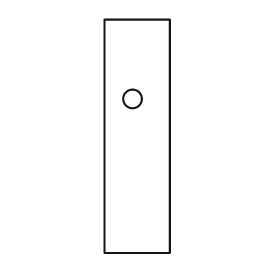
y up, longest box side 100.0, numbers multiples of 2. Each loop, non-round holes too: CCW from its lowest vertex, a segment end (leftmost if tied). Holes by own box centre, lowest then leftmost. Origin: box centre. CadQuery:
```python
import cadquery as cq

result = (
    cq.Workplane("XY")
    .moveTo(-14.0, -50.0)
    .lineTo(14.0, -50.0)
    .lineTo(14.0, 50.0)
    .lineTo(-14.0, 50.0)
    .close()
    .moveTo(-2.0, 16.0)
    .circle(4.0)
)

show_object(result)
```